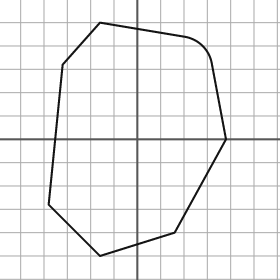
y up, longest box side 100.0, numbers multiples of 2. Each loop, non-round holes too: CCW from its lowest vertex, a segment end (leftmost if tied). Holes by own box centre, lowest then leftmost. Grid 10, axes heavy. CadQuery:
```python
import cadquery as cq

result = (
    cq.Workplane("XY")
    .moveTo(-16.0, -50.0)
    .lineTo(16.0, -40.0)
    .lineTo(38.0, 0.0)
    .lineTo(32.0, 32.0)
    .threePointArc((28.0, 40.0), (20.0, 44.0))
    .lineTo(-16.0, 50.0)
    .lineTo(-32.0, 32.0)
    .lineTo(-38.0, -28.0)
    .close()
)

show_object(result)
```